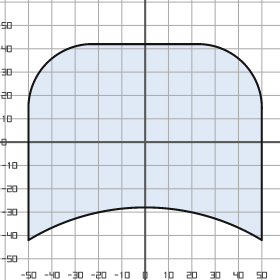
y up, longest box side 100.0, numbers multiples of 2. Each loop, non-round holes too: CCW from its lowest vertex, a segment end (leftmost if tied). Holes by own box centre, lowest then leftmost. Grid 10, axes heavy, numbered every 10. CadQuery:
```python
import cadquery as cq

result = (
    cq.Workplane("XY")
    .moveTo(-50.0, -42.0)
    .threePointArc((0.0, -28.0), (50.0, -42.0))
    .lineTo(50.0, 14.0)
    .threePointArc((42.0, 34.0), (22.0, 42.0))
    .lineTo(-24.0, 42.0)
    .threePointArc((-42.0, 34.0), (-50.0, 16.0))
    .close()
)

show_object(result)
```